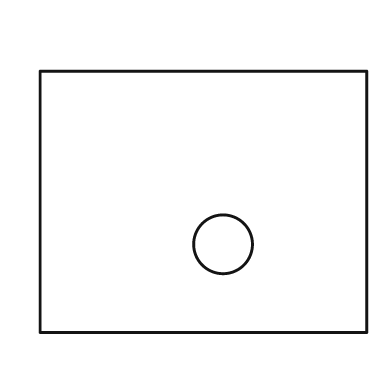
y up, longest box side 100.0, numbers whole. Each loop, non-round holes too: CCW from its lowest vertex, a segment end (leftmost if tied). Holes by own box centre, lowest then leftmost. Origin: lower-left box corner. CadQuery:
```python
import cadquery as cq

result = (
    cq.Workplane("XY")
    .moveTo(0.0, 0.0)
    .lineTo(100.0, 0.0)
    .lineTo(100.0, 80.0)
    .lineTo(0.0, 80.0)
    .close()
    .moveTo(56.0, 27.0)
    .circle(9.0)
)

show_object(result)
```